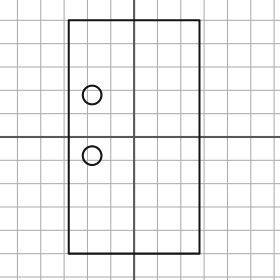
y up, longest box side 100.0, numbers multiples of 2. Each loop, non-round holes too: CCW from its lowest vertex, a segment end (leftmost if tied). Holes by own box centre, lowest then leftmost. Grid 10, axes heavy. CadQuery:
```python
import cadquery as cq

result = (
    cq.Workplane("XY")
    .moveTo(-28.0, -50.0)
    .lineTo(28.0, -50.0)
    .lineTo(28.0, 50.0)
    .lineTo(-28.0, 50.0)
    .close()
    .moveTo(-18.0, -8.0)
    .circle(4.0)
    .moveTo(-18.0, 18.0)
    .circle(4.0)
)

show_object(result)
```